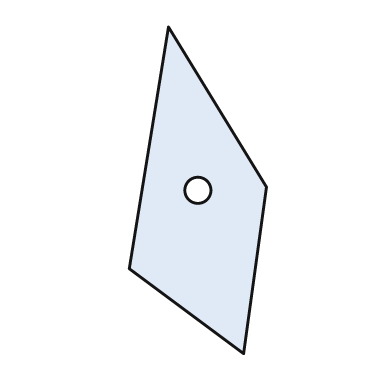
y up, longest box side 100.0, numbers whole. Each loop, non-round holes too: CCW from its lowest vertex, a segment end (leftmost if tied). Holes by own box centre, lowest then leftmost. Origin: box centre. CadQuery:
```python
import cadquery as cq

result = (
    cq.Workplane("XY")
    .moveTo(14.0, -50.0)
    .lineTo(21.0, 1.0)
    .lineTo(-9.0, 50.0)
    .lineTo(-21.0, -24.0)
    .close()
    .moveTo(0.0, 0.0)
    .circle(4.0)
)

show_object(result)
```